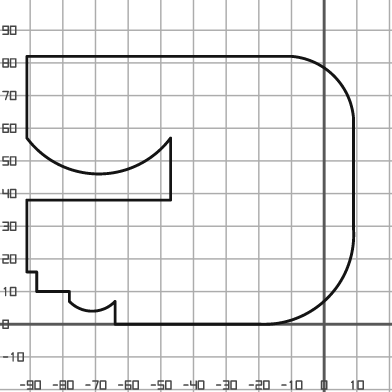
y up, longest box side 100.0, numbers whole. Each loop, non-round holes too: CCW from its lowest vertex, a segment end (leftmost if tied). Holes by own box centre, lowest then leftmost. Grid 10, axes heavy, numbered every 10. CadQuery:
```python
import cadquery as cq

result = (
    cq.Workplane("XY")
    .moveTo(-64.0, 0.0)
    .lineTo(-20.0, 0.0)
    .threePointArc((1.0, 8.0), (9.0, 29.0))
    .lineTo(9.0, 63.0)
    .threePointArc((3.0, 76.0), (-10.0, 82.0))
    .lineTo(-91.0, 82.0)
    .lineTo(-91.0, 57.0)
    .threePointArc((-69.0, 46.0), (-47.0, 57.0))
    .lineTo(-47.0, 38.0)
    .lineTo(-91.0, 38.0)
    .lineTo(-91.0, 16.0)
    .lineTo(-88.0, 16.0)
    .lineTo(-88.0, 10.0)
    .lineTo(-78.0, 10.0)
    .lineTo(-78.0, 7.0)
    .threePointArc((-71.0, 4.0), (-64.0, 7.0))
    .close()
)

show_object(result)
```